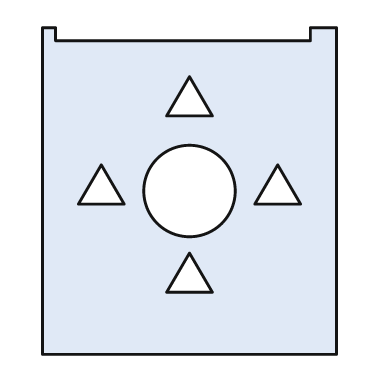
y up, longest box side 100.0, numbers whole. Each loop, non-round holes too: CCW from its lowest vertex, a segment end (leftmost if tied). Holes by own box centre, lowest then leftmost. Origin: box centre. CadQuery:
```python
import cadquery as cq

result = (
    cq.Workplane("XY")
    .moveTo(-45.0, -50.0)
    .lineTo(45.0, -50.0)
    .lineTo(45.0, 50.0)
    .lineTo(37.0, 50.0)
    .lineTo(37.0, 46.0)
    .lineTo(-41.0, 46.0)
    .lineTo(-41.0, 50.0)
    .lineTo(-45.0, 50.0)
    .close()
    .moveTo(-7.0, -31.0)
    .lineTo(7.0, -31.0)
    .lineTo(0.0, -19.0)
    .close()
    .moveTo(0.0, 0.0)
    .circle(14.0)
    .moveTo(-34.0, -4.0)
    .lineTo(-20.0, -4.0)
    .lineTo(-27.0, 8.0)
    .close()
    .moveTo(20.0, -4.0)
    .lineTo(34.0, -4.0)
    .lineTo(27.0, 8.0)
    .close()
    .moveTo(-7.0, 23.0)
    .lineTo(7.0, 23.0)
    .lineTo(0.0, 35.0)
    .close()
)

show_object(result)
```